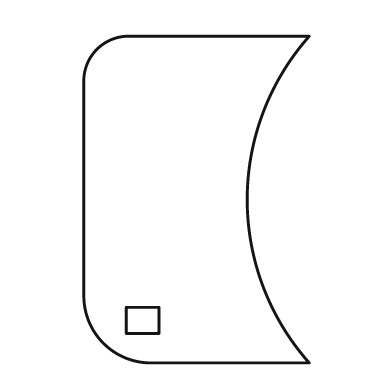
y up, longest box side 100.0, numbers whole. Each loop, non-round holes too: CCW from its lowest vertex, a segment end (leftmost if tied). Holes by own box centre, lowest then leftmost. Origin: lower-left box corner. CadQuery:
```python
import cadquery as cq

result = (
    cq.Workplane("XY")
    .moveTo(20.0, 0.0)
    .lineTo(69.0, 0.0)
    .threePointArc((50.0, 50.0), (69.0, 100.0))
    .lineTo(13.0, 100.0)
    .threePointArc((4.0, 96.0), (0.0, 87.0))
    .lineTo(0.0, 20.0)
    .threePointArc((6.0, 6.0), (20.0, 0.0))
    .close()
    .moveTo(13.0, 9.0)
    .lineTo(23.0, 9.0)
    .lineTo(23.0, 17.0)
    .lineTo(13.0, 17.0)
    .close()
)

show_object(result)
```